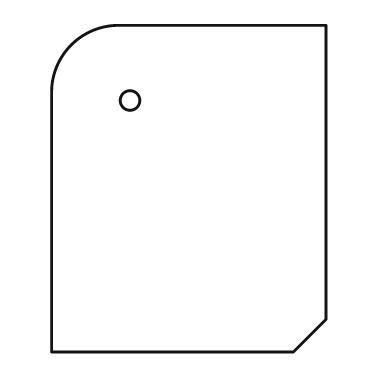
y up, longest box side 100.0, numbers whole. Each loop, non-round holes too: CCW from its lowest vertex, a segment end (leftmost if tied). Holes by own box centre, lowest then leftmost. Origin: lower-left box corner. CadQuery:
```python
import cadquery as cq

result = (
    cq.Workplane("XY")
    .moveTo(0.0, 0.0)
    .lineTo(74.0, 0.0)
    .lineTo(84.0, 10.0)
    .lineTo(84.0, 100.0)
    .lineTo(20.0, 100.0)
    .threePointArc((6.0, 94.0), (0.0, 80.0))
    .close()
    .moveTo(24.0, 77.0)
    .circle(3.0)
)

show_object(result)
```